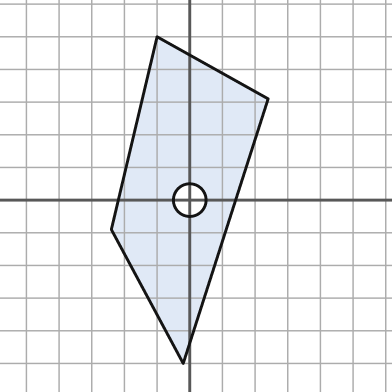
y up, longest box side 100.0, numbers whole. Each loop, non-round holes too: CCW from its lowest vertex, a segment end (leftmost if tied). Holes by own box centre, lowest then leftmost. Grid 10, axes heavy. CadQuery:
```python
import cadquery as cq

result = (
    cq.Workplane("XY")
    .moveTo(-2.0, -50.0)
    .lineTo(24.0, 31.0)
    .lineTo(-10.0, 50.0)
    .lineTo(-24.0, -9.0)
    .close()
    .moveTo(0.0, 0.0)
    .circle(5.0)
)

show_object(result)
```